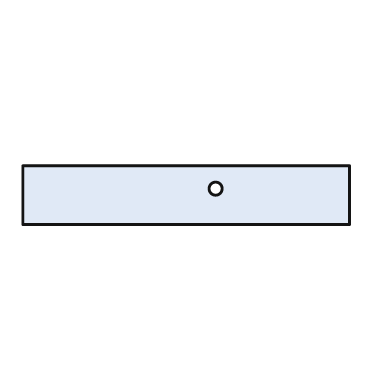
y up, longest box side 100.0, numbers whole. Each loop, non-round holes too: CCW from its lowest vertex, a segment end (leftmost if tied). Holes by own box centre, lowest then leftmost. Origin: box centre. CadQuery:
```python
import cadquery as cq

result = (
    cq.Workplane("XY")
    .moveTo(-50.0, -9.0)
    .lineTo(50.0, -9.0)
    .lineTo(50.0, 9.0)
    .lineTo(-50.0, 9.0)
    .close()
    .moveTo(9.0, 2.0)
    .circle(2.0)
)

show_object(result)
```